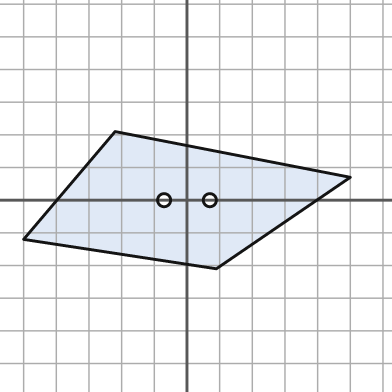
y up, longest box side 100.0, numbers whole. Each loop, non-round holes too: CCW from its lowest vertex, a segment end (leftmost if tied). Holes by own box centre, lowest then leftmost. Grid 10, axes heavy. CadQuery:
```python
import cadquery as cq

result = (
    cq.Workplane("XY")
    .moveTo(9.0, -21.0)
    .lineTo(50.0, 7.0)
    .lineTo(-22.0, 21.0)
    .lineTo(-50.0, -12.0)
    .close()
    .moveTo(-7.0, 0.0)
    .circle(2.0)
    .moveTo(7.0, 0.0)
    .circle(2.0)
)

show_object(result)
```